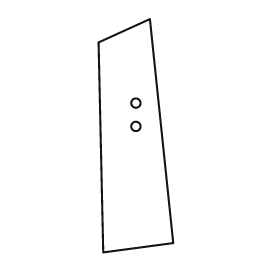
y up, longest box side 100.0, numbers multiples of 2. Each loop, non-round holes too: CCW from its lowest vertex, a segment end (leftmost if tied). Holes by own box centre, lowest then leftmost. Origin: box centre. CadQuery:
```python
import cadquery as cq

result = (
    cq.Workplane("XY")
    .moveTo(-14.0, -50.0)
    .lineTo(16.0, -46.0)
    .lineTo(6.0, 50.0)
    .lineTo(-16.0, 40.0)
    .close()
    .moveTo(0.0, 4.0)
    .circle(2.0)
    .moveTo(0.0, 14.0)
    .circle(2.0)
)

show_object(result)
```